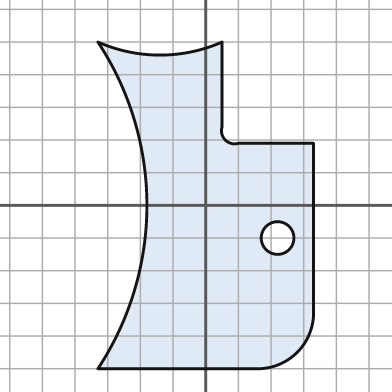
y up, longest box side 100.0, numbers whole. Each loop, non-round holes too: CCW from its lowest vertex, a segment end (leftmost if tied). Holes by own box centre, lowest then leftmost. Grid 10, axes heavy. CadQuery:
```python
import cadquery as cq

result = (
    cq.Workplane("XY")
    .moveTo(-33.0, -50.0)
    .lineTo(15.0, -50.0)
    .threePointArc((28.0, -45.0), (33.0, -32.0))
    .lineTo(33.0, 19.0)
    .lineTo(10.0, 19.0)
    .threePointArc((6.0, 20.0), (5.0, 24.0))
    .lineTo(5.0, 50.0)
    .threePointArc((-14.0, 46.0), (-33.0, 50.0))
    .threePointArc((-18.0, 0.0), (-33.0, -50.0))
    .close()
    .moveTo(22.0, -10.0)
    .circle(5.0)
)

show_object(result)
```